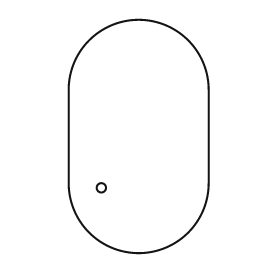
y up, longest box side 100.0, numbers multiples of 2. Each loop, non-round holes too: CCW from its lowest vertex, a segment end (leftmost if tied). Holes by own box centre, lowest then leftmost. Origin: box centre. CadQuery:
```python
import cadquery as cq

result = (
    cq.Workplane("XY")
    .moveTo(-30.0, -20.0)
    .threePointArc((0.0, -50.0), (30.0, -20.0))
    .lineTo(30.0, 20.0)
    .threePointArc((0.0, 50.0), (-30.0, 20.0))
    .close()
    .moveTo(-16.0, -22.0)
    .circle(2.0)
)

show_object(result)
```